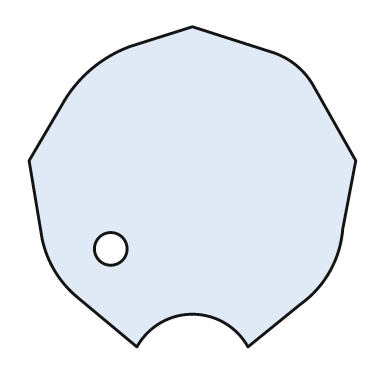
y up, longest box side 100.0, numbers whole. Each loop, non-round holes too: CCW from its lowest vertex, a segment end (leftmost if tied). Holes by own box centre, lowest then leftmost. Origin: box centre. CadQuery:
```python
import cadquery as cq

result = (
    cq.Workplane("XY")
    .moveTo(-17.0, -49.0)
    .threePointArc((0.0, -39.0), (17.0, -49.0))
    .lineTo(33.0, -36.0)
    .threePointArc((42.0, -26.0), (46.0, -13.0))
    .lineTo(50.0, 8.0)
    .lineTo(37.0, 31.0)
    .threePointArc((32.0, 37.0), (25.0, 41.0))
    .lineTo(0.0, 49.0)
    .lineTo(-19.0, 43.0)
    .threePointArc((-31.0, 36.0), (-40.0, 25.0))
    .lineTo(-50.0, 8.0)
    .lineTo(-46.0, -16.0)
    .threePointArc((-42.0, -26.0), (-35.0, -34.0))
    .close()
    .moveTo(-25.0, -19.0)
    .circle(5.0)
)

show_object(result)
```